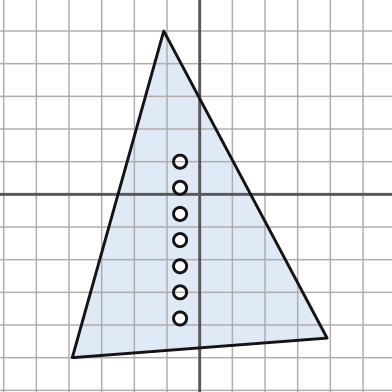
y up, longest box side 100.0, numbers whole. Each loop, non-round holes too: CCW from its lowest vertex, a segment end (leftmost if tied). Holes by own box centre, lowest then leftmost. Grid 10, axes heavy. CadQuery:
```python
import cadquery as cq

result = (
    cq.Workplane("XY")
    .moveTo(-39.0, -50.0)
    .lineTo(39.0, -44.0)
    .lineTo(-11.0, 50.0)
    .close()
    .moveTo(-6.0, -38.0)
    .circle(2.0)
    .moveTo(-6.0, -30.0)
    .circle(2.0)
    .moveTo(-6.0, -22.0)
    .circle(2.0)
    .moveTo(-6.0, -14.0)
    .circle(2.0)
    .moveTo(-6.0, -6.0)
    .circle(2.0)
    .moveTo(-6.0, 2.0)
    .circle(2.0)
    .moveTo(-6.0, 10.0)
    .circle(2.0)
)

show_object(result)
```